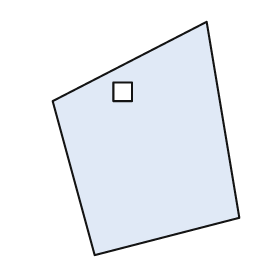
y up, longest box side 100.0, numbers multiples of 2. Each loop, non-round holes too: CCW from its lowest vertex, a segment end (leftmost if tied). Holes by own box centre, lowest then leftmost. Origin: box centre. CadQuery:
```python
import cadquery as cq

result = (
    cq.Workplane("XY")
    .moveTo(-22.0, -50.0)
    .lineTo(40.0, -34.0)
    .lineTo(26.0, 50.0)
    .lineTo(-40.0, 16.0)
    .close()
    .moveTo(-14.0, 16.0)
    .lineTo(-6.0, 16.0)
    .lineTo(-6.0, 24.0)
    .lineTo(-14.0, 24.0)
    .close()
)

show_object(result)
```